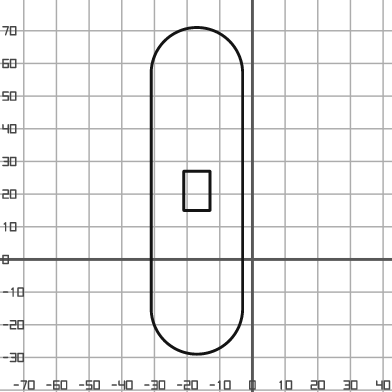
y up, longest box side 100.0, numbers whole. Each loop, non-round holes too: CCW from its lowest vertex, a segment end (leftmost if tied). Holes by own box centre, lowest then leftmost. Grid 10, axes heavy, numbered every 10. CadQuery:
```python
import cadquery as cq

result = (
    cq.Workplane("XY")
    .moveTo(-31.0, -15.0)
    .threePointArc((-17.0, -29.0), (-3.0, -15.0))
    .lineTo(-3.0, 57.0)
    .threePointArc((-17.0, 71.0), (-31.0, 57.0))
    .close()
    .moveTo(-21.0, 15.0)
    .lineTo(-13.0, 15.0)
    .lineTo(-13.0, 27.0)
    .lineTo(-21.0, 27.0)
    .close()
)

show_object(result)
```